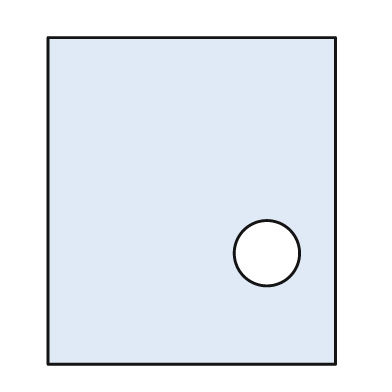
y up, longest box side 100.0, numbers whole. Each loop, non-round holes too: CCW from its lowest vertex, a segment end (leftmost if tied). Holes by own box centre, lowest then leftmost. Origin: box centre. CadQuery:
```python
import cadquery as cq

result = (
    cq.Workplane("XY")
    .moveTo(-44.0, -50.0)
    .lineTo(44.0, -50.0)
    .lineTo(44.0, 50.0)
    .lineTo(-44.0, 50.0)
    .close()
    .moveTo(23.0, -16.0)
    .circle(10.0)
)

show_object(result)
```